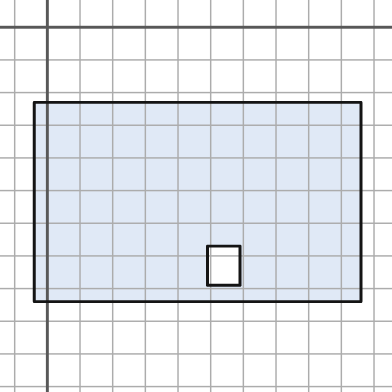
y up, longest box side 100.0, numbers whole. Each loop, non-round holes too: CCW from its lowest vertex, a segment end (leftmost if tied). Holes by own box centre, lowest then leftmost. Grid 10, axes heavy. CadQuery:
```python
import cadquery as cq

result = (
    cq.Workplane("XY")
    .moveTo(-4.0, -84.0)
    .lineTo(96.0, -84.0)
    .lineTo(96.0, -23.0)
    .lineTo(-4.0, -23.0)
    .close()
    .moveTo(49.0, -79.0)
    .lineTo(59.0, -79.0)
    .lineTo(59.0, -67.0)
    .lineTo(49.0, -67.0)
    .close()
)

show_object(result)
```